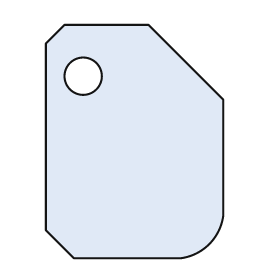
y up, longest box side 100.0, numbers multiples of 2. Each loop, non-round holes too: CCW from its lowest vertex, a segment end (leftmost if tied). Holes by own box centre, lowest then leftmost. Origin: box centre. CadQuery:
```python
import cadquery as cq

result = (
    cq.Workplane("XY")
    .moveTo(-26.0, -50.0)
    .lineTo(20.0, -50.0)
    .threePointArc((32.0, -44.0), (38.0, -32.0))
    .lineTo(38.0, 18.0)
    .lineTo(6.0, 50.0)
    .lineTo(-30.0, 50.0)
    .lineTo(-38.0, 42.0)
    .lineTo(-38.0, -38.0)
    .close()
    .moveTo(-22.0, 28.0)
    .circle(8.0)
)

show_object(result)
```